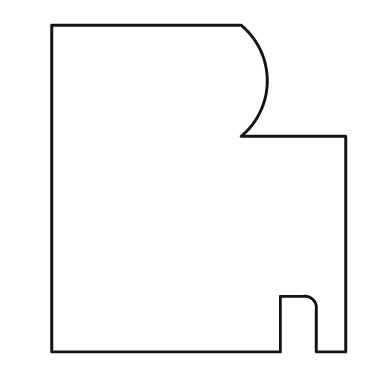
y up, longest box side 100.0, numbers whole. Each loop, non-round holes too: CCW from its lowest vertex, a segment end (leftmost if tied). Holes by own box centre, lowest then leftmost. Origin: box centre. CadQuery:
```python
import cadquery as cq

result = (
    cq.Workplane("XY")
    .moveTo(-45.0, -50.0)
    .lineTo(25.0, -50.0)
    .lineTo(25.0, -33.0)
    .lineTo(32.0, -33.0)
    .threePointArc((35.0, -34.0), (36.0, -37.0))
    .lineTo(36.0, -50.0)
    .lineTo(45.0, -50.0)
    .lineTo(45.0, 16.0)
    .lineTo(13.0, 16.0)
    .threePointArc((21.0, 33.0), (13.0, 50.0))
    .lineTo(-45.0, 50.0)
    .close()
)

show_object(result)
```